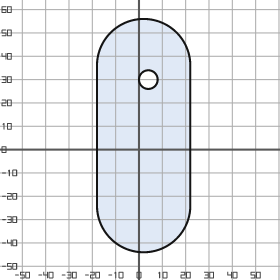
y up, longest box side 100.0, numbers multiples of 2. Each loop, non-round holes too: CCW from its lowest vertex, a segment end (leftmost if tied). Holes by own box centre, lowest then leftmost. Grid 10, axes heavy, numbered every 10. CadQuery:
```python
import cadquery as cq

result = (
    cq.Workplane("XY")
    .moveTo(-18.0, -24.0)
    .threePointArc((2.0, -44.0), (22.0, -24.0))
    .lineTo(22.0, 36.0)
    .threePointArc((2.0, 56.0), (-18.0, 36.0))
    .close()
    .moveTo(4.0, 30.0)
    .circle(4.0)
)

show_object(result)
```